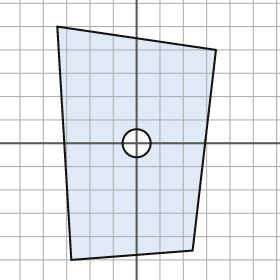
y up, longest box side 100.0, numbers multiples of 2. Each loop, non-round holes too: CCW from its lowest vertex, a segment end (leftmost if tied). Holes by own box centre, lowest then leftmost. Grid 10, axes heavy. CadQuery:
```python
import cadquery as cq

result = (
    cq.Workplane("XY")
    .moveTo(-28.0, -50.0)
    .lineTo(24.0, -46.0)
    .lineTo(34.0, 40.0)
    .lineTo(-34.0, 50.0)
    .close()
    .moveTo(0.0, 0.0)
    .circle(6.0)
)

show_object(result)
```